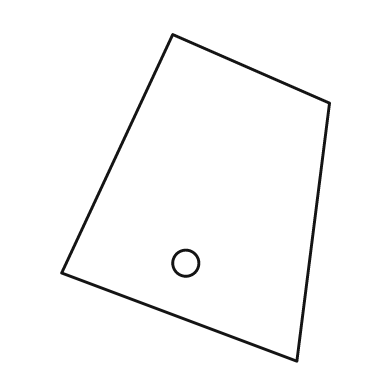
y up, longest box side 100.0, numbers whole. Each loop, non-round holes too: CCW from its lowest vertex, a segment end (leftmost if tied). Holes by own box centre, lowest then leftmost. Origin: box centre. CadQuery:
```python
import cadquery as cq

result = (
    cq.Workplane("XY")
    .moveTo(31.0, -50.0)
    .lineTo(41.0, 29.0)
    .lineTo(-7.0, 50.0)
    .lineTo(-41.0, -23.0)
    .close()
    .moveTo(-3.0, -20.0)
    .circle(4.0)
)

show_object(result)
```